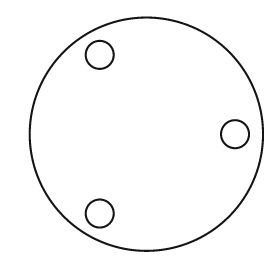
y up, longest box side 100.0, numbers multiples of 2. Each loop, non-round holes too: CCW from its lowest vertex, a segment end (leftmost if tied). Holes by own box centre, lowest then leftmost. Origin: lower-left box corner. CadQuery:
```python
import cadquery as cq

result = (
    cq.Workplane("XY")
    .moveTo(50.0, 50.0)
    .circle(50.0)
    .moveTo(30.0, 16.0)
    .circle(6.0)
    .moveTo(88.0, 50.0)
    .circle(6.0)
    .moveTo(30.0, 84.0)
    .circle(6.0)
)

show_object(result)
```